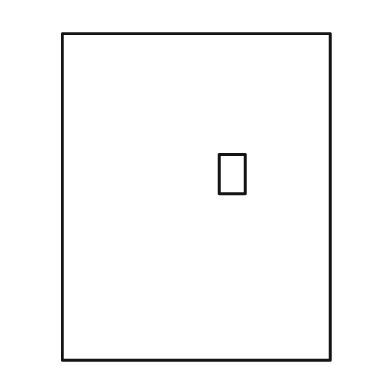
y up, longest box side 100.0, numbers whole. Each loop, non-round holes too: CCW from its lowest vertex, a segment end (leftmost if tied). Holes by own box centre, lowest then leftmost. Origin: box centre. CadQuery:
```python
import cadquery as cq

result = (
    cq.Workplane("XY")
    .moveTo(-41.0, -50.0)
    .lineTo(41.0, -50.0)
    .lineTo(41.0, 50.0)
    .lineTo(-41.0, 50.0)
    .close()
    .moveTo(7.0, 1.0)
    .lineTo(15.0, 1.0)
    .lineTo(15.0, 13.0)
    .lineTo(7.0, 13.0)
    .close()
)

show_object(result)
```